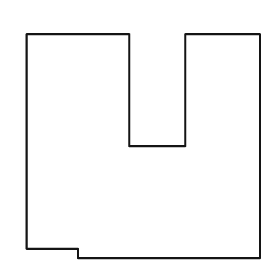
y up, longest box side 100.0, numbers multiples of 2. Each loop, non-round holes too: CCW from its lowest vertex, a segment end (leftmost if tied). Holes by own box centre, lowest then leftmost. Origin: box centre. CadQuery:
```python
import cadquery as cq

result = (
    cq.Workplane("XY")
    .moveTo(-28.0, -48.0)
    .lineTo(50.0, -48.0)
    .lineTo(50.0, 48.0)
    .lineTo(18.0, 48.0)
    .lineTo(18.0, 0.0)
    .lineTo(-6.0, 0.0)
    .lineTo(-6.0, 48.0)
    .lineTo(-50.0, 48.0)
    .lineTo(-50.0, -44.0)
    .lineTo(-28.0, -44.0)
    .close()
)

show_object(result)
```